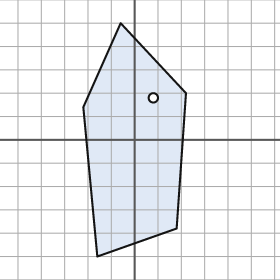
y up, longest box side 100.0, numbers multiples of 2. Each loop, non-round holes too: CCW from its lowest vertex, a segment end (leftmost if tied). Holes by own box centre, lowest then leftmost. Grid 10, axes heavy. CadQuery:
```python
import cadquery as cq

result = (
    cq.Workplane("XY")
    .moveTo(-16.0, -50.0)
    .lineTo(18.0, -38.0)
    .lineTo(22.0, 20.0)
    .lineTo(-6.0, 50.0)
    .lineTo(-22.0, 14.0)
    .close()
    .moveTo(8.0, 18.0)
    .circle(2.0)
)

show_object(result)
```